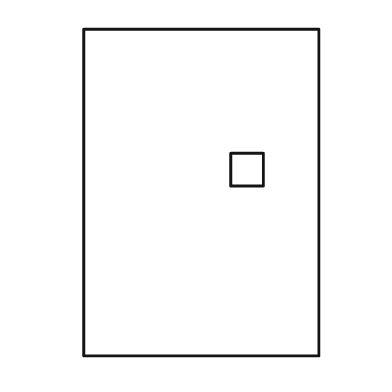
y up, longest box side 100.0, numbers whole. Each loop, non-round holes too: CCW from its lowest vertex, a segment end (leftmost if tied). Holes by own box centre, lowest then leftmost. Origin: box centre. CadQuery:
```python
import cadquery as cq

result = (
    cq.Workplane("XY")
    .moveTo(-36.0, -50.0)
    .lineTo(36.0, -50.0)
    .lineTo(36.0, 50.0)
    .lineTo(-36.0, 50.0)
    .close()
    .moveTo(9.0, 2.0)
    .lineTo(19.0, 2.0)
    .lineTo(19.0, 12.0)
    .lineTo(9.0, 12.0)
    .close()
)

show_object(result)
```